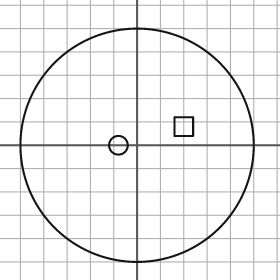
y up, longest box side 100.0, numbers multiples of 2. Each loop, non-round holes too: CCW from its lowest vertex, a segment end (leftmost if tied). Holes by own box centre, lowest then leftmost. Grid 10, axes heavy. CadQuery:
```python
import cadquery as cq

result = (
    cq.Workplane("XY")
    .moveTo(0.0, 0.0)
    .circle(50.0)
    .moveTo(-8.0, 0.0)
    .circle(4.0)
    .moveTo(16.0, 4.0)
    .lineTo(24.0, 4.0)
    .lineTo(24.0, 12.0)
    .lineTo(16.0, 12.0)
    .close()
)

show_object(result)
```